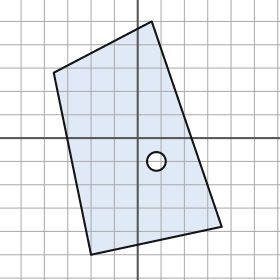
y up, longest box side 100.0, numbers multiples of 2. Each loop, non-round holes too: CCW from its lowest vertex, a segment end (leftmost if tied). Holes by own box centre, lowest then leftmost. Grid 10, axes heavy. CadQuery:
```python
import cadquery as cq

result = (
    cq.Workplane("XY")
    .moveTo(-20.0, -50.0)
    .lineTo(36.0, -38.0)
    .lineTo(6.0, 50.0)
    .lineTo(-36.0, 28.0)
    .close()
    .moveTo(8.0, -10.0)
    .circle(4.0)
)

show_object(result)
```